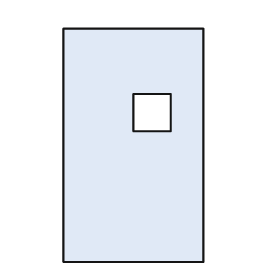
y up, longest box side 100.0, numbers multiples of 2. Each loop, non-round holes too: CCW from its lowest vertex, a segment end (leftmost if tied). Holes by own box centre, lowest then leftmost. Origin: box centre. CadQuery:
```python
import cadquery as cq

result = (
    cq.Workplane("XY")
    .moveTo(-30.0, -50.0)
    .lineTo(30.0, -50.0)
    .lineTo(30.0, 50.0)
    .lineTo(-30.0, 50.0)
    .close()
    .moveTo(0.0, 6.0)
    .lineTo(16.0, 6.0)
    .lineTo(16.0, 22.0)
    .lineTo(0.0, 22.0)
    .close()
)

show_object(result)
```